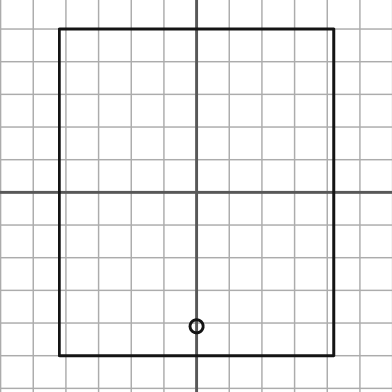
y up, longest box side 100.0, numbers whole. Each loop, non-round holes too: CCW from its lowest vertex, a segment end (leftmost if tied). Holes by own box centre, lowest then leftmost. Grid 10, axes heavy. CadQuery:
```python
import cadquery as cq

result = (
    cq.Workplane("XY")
    .moveTo(-42.0, -50.0)
    .lineTo(42.0, -50.0)
    .lineTo(42.0, 50.0)
    .lineTo(-42.0, 50.0)
    .close()
    .moveTo(0.0, -41.0)
    .circle(2.0)
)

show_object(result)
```